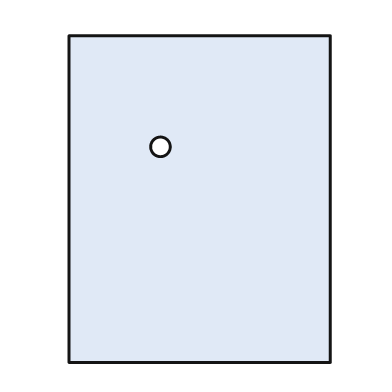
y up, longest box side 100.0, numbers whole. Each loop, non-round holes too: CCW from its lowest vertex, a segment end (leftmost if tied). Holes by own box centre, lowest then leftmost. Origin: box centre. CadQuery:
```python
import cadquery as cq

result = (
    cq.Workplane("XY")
    .moveTo(-40.0, -50.0)
    .lineTo(40.0, -50.0)
    .lineTo(40.0, 50.0)
    .lineTo(-40.0, 50.0)
    .close()
    .moveTo(-12.0, 16.0)
    .circle(3.0)
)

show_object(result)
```